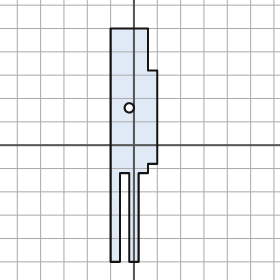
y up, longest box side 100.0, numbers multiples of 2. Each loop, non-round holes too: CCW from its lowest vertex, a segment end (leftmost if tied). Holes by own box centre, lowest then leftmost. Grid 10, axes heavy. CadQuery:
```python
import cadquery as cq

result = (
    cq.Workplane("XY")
    .moveTo(-10.0, -50.0)
    .lineTo(-6.0, -50.0)
    .lineTo(-6.0, -12.0)
    .lineTo(-2.0, -12.0)
    .lineTo(-2.0, -50.0)
    .lineTo(2.0, -50.0)
    .lineTo(2.0, -12.0)
    .lineTo(6.0, -12.0)
    .lineTo(6.0, -8.0)
    .lineTo(10.0, -8.0)
    .lineTo(10.0, 32.0)
    .lineTo(6.0, 32.0)
    .lineTo(6.0, 50.0)
    .lineTo(-10.0, 50.0)
    .close()
    .moveTo(-2.0, 16.0)
    .circle(2.0)
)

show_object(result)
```